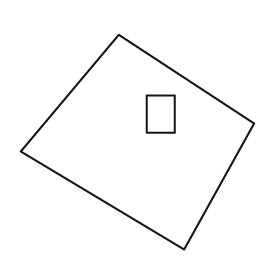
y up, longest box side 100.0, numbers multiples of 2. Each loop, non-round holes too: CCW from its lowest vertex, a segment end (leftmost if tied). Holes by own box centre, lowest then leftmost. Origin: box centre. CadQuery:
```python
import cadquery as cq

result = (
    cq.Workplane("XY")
    .moveTo(20.0, -46.0)
    .lineTo(50.0, 8.0)
    .lineTo(-8.0, 46.0)
    .lineTo(-50.0, -4.0)
    .close()
    .moveTo(4.0, 4.0)
    .lineTo(16.0, 4.0)
    .lineTo(16.0, 20.0)
    .lineTo(4.0, 20.0)
    .close()
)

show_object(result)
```